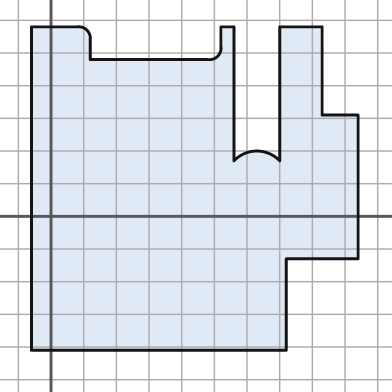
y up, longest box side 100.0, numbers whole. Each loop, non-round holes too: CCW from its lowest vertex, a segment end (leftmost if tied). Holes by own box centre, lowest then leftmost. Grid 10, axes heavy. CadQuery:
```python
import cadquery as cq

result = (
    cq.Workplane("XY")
    .moveTo(-6.0, -41.0)
    .lineTo(72.0, -41.0)
    .lineTo(72.0, -13.0)
    .lineTo(94.0, -13.0)
    .lineTo(94.0, 31.0)
    .lineTo(83.0, 31.0)
    .lineTo(83.0, 58.0)
    .lineTo(70.0, 58.0)
    .lineTo(70.0, 17.0)
    .threePointArc((63.0, 20.0), (56.0, 17.0))
    .lineTo(56.0, 58.0)
    .lineTo(52.0, 58.0)
    .lineTo(52.0, 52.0)
    .threePointArc((51.0, 49.0), (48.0, 48.0))
    .lineTo(12.0, 48.0)
    .lineTo(12.0, 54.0)
    .threePointArc((11.0, 57.0), (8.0, 58.0))
    .lineTo(-6.0, 58.0)
    .close()
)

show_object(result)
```